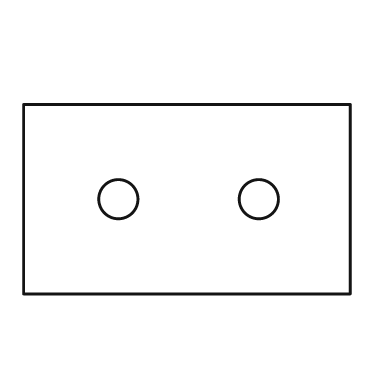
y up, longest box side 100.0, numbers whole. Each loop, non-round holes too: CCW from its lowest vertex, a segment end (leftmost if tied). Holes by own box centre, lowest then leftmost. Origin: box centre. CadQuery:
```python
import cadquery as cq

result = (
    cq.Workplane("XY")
    .moveTo(-50.0, -29.0)
    .lineTo(50.0, -29.0)
    .lineTo(50.0, 29.0)
    .lineTo(-50.0, 29.0)
    .close()
    .moveTo(-21.0, 0.0)
    .circle(6.0)
    .moveTo(22.0, 0.0)
    .circle(6.0)
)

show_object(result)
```